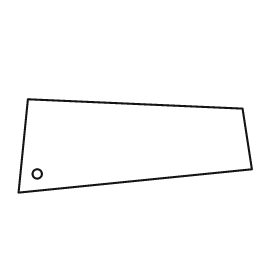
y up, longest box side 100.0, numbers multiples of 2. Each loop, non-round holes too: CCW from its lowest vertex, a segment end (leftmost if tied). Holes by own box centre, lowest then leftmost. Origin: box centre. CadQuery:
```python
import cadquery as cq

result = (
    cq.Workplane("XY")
    .moveTo(-50.0, -20.0)
    .lineTo(50.0, -10.0)
    .lineTo(46.0, 16.0)
    .lineTo(-46.0, 20.0)
    .close()
    .moveTo(-42.0, -12.0)
    .circle(2.0)
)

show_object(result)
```